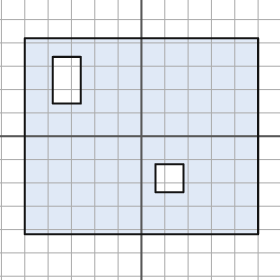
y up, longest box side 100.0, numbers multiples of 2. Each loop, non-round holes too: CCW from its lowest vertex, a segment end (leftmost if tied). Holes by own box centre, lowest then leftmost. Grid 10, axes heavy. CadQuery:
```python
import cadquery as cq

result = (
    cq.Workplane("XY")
    .moveTo(-50.0, -42.0)
    .lineTo(50.0, -42.0)
    .lineTo(50.0, 42.0)
    .lineTo(-50.0, 42.0)
    .close()
    .moveTo(6.0, -24.0)
    .lineTo(18.0, -24.0)
    .lineTo(18.0, -12.0)
    .lineTo(6.0, -12.0)
    .close()
    .moveTo(-38.0, 14.0)
    .lineTo(-26.0, 14.0)
    .lineTo(-26.0, 34.0)
    .lineTo(-38.0, 34.0)
    .close()
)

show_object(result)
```